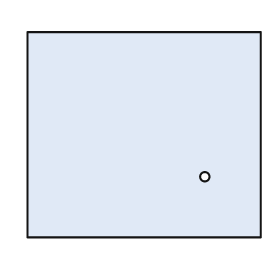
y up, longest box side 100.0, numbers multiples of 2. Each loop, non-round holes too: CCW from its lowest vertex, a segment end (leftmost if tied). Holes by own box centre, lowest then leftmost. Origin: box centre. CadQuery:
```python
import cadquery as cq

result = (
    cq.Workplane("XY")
    .moveTo(-50.0, -44.0)
    .lineTo(50.0, -44.0)
    .lineTo(50.0, 44.0)
    .lineTo(-50.0, 44.0)
    .close()
    .moveTo(26.0, -18.0)
    .circle(2.0)
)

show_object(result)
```